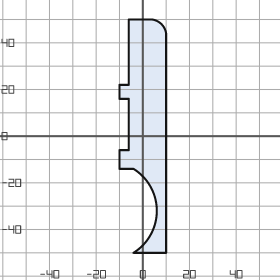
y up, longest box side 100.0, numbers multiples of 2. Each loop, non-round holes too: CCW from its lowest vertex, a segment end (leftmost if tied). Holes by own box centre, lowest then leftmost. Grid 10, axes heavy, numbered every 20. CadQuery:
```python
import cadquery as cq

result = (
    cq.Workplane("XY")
    .moveTo(-4.0, -50.0)
    .lineTo(10.0, -50.0)
    .lineTo(10.0, 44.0)
    .threePointArc((8.0, 48.0), (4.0, 50.0))
    .lineTo(-6.0, 50.0)
    .lineTo(-6.0, 22.0)
    .lineTo(-10.0, 22.0)
    .lineTo(-10.0, 16.0)
    .lineTo(-6.0, 16.0)
    .lineTo(-6.0, -6.0)
    .lineTo(-10.0, -6.0)
    .lineTo(-10.0, -14.0)
    .lineTo(-4.0, -14.0)
    .threePointArc((6.0, -32.0), (-4.0, -50.0))
    .close()
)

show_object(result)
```